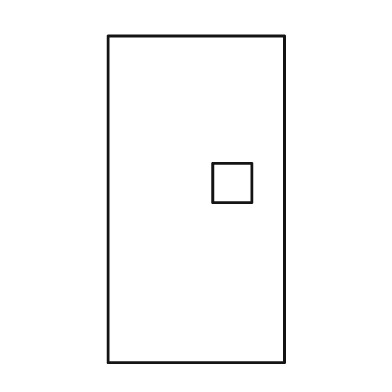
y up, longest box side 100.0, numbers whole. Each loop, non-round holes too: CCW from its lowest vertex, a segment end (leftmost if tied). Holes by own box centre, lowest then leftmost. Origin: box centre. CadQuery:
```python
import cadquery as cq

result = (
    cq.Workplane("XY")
    .moveTo(-27.0, -50.0)
    .lineTo(27.0, -50.0)
    .lineTo(27.0, 50.0)
    .lineTo(-27.0, 50.0)
    .close()
    .moveTo(5.0, -1.0)
    .lineTo(17.0, -1.0)
    .lineTo(17.0, 11.0)
    .lineTo(5.0, 11.0)
    .close()
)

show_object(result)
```